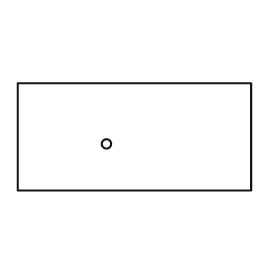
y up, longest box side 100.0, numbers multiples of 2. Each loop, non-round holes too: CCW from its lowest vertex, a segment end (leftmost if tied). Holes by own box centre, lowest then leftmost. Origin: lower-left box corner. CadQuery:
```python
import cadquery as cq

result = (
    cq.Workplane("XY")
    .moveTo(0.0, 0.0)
    .lineTo(100.0, 0.0)
    .lineTo(100.0, 46.0)
    .lineTo(0.0, 46.0)
    .close()
    .moveTo(38.0, 20.0)
    .circle(2.0)
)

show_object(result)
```